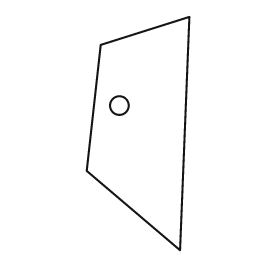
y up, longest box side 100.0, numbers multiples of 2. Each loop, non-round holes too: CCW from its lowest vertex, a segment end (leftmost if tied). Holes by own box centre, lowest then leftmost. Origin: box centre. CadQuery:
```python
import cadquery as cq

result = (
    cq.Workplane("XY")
    .moveTo(18.0, -50.0)
    .lineTo(22.0, 50.0)
    .lineTo(-16.0, 38.0)
    .lineTo(-22.0, -16.0)
    .close()
    .moveTo(-8.0, 12.0)
    .circle(4.0)
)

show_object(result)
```